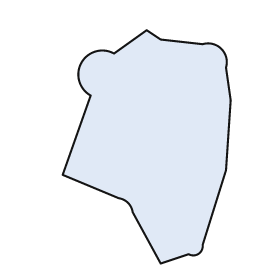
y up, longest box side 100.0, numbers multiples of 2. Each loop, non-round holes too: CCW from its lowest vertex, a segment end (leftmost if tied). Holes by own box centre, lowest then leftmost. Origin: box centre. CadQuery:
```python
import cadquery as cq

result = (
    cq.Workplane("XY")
    .moveTo(6.0, -50.0)
    .lineTo(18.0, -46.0)
    .threePointArc((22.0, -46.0), (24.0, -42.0))
    .lineTo(34.0, -10.0)
    .lineTo(36.0, 20.0)
    .lineTo(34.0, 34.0)
    .threePointArc((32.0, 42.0), (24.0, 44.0))
    .lineTo(6.0, 46.0)
    .lineTo(0.0, 50.0)
    .lineTo(-14.0, 40.0)
    .threePointArc((-28.0, 36.0), (-24.0, 22.0))
    .lineTo(-36.0, -12.0)
    .lineTo(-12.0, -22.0)
    .threePointArc((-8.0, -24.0), (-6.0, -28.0))
    .close()
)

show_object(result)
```